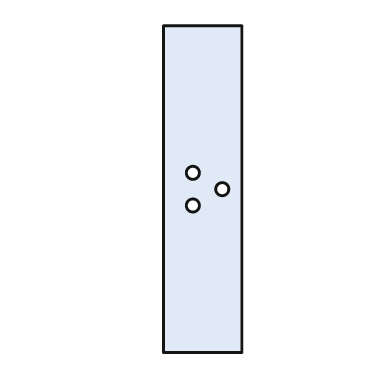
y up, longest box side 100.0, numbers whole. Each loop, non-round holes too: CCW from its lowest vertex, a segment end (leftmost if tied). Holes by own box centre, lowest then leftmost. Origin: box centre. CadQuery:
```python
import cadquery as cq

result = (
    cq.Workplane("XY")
    .moveTo(-12.0, -50.0)
    .lineTo(12.0, -50.0)
    .lineTo(12.0, 50.0)
    .lineTo(-12.0, 50.0)
    .close()
    .moveTo(-3.0, -5.0)
    .circle(2.0)
    .moveTo(6.0, 0.0)
    .circle(2.0)
    .moveTo(-3.0, 5.0)
    .circle(2.0)
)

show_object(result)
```